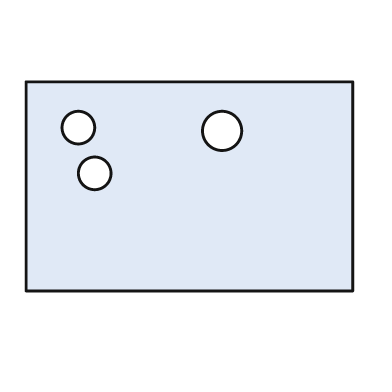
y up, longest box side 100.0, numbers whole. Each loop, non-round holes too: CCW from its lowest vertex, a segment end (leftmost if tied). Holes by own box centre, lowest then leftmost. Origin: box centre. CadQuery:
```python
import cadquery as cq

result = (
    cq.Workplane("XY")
    .moveTo(-50.0, -32.0)
    .lineTo(50.0, -32.0)
    .lineTo(50.0, 32.0)
    .lineTo(-50.0, 32.0)
    .close()
    .moveTo(-29.0, 4.0)
    .circle(5.0)
    .moveTo(10.0, 17.0)
    .circle(6.0)
    .moveTo(-34.0, 18.0)
    .circle(5.0)
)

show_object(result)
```